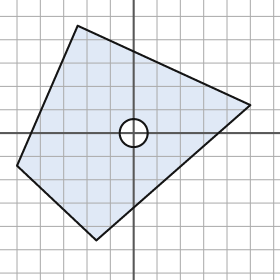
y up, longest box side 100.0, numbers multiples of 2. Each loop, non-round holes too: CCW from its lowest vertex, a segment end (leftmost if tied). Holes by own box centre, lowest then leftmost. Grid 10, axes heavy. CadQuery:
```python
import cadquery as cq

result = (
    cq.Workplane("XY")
    .moveTo(-16.0, -46.0)
    .lineTo(50.0, 12.0)
    .lineTo(-24.0, 46.0)
    .lineTo(-50.0, -14.0)
    .close()
    .moveTo(0.0, 0.0)
    .circle(6.0)
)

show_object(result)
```